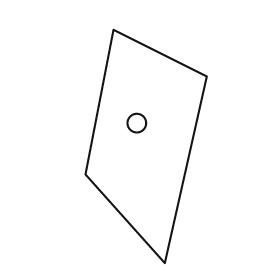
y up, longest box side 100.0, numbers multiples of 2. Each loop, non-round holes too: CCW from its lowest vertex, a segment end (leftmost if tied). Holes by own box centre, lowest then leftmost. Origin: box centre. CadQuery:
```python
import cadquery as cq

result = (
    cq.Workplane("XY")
    .moveTo(8.0, -50.0)
    .lineTo(26.0, 30.0)
    .lineTo(-14.0, 50.0)
    .lineTo(-26.0, -12.0)
    .close()
    .moveTo(-4.0, 10.0)
    .circle(4.0)
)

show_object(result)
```